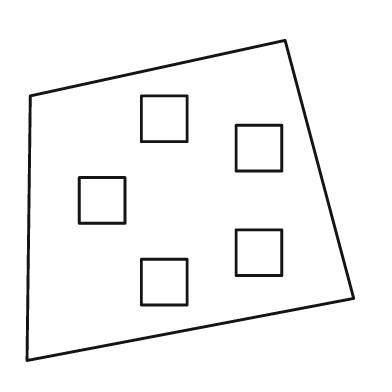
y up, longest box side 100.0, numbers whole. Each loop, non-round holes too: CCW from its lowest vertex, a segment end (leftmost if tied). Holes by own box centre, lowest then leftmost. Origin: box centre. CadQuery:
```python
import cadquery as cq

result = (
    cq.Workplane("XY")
    .moveTo(-50.0, -49.0)
    .lineTo(50.0, -30.0)
    .lineTo(29.0, 49.0)
    .lineTo(-49.0, 32.0)
    .close()
    .moveTo(-15.0, -32.0)
    .lineTo(-1.0, -32.0)
    .lineTo(-1.0, -18.0)
    .lineTo(-15.0, -18.0)
    .close()
    .moveTo(14.0, -23.0)
    .lineTo(28.0, -23.0)
    .lineTo(28.0, -9.0)
    .lineTo(14.0, -9.0)
    .close()
    .moveTo(-34.0, -7.0)
    .lineTo(-20.0, -7.0)
    .lineTo(-20.0, 7.0)
    .lineTo(-34.0, 7.0)
    .close()
    .moveTo(14.0, 9.0)
    .lineTo(28.0, 9.0)
    .lineTo(28.0, 23.0)
    .lineTo(14.0, 23.0)
    .close()
    .moveTo(-15.0, 18.0)
    .lineTo(-1.0, 18.0)
    .lineTo(-1.0, 32.0)
    .lineTo(-15.0, 32.0)
    .close()
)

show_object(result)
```